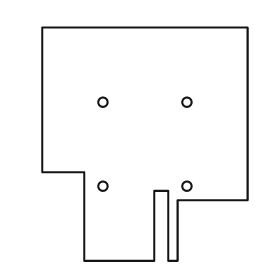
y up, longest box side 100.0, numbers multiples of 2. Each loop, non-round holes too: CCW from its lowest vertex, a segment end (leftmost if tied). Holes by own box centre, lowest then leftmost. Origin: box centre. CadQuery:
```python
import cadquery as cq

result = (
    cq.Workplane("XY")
    .moveTo(-26.0, -50.0)
    .lineTo(4.0, -50.0)
    .lineTo(4.0, -20.0)
    .lineTo(10.0, -20.0)
    .lineTo(10.0, -50.0)
    .lineTo(14.0, -50.0)
    .lineTo(14.0, -24.0)
    .lineTo(44.0, -24.0)
    .lineTo(44.0, 50.0)
    .lineTo(-44.0, 50.0)
    .lineTo(-44.0, -12.0)
    .lineTo(-26.0, -12.0)
    .close()
    .moveTo(-18.0, -18.0)
    .circle(2.0)
    .moveTo(18.0, -18.0)
    .circle(2.0)
    .moveTo(-18.0, 18.0)
    .circle(2.0)
    .moveTo(18.0, 18.0)
    .circle(2.0)
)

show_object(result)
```